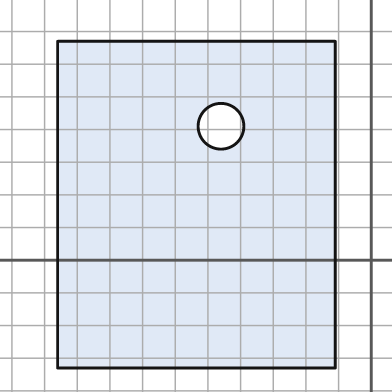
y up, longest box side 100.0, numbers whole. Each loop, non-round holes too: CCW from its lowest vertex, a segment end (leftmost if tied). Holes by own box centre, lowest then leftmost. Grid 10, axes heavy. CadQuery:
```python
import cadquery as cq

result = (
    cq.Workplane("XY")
    .moveTo(-96.0, -33.0)
    .lineTo(-11.0, -33.0)
    .lineTo(-11.0, 67.0)
    .lineTo(-96.0, 67.0)
    .close()
    .moveTo(-46.0, 41.0)
    .circle(7.0)
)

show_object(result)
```